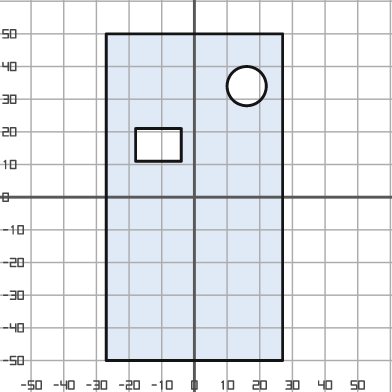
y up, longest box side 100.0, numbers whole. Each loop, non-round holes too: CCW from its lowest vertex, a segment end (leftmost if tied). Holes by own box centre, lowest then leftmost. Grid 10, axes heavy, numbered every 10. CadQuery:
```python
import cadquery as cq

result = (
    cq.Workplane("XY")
    .moveTo(-27.0, -50.0)
    .lineTo(27.0, -50.0)
    .lineTo(27.0, 50.0)
    .lineTo(-27.0, 50.0)
    .close()
    .moveTo(-18.0, 11.0)
    .lineTo(-4.0, 11.0)
    .lineTo(-4.0, 21.0)
    .lineTo(-18.0, 21.0)
    .close()
    .moveTo(16.0, 34.0)
    .circle(6.0)
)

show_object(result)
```